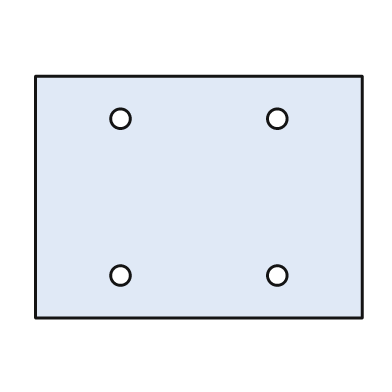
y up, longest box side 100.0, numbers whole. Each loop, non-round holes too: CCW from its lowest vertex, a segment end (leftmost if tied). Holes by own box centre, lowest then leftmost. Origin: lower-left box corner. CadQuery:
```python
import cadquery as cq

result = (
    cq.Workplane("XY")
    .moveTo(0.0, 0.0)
    .lineTo(100.0, 0.0)
    .lineTo(100.0, 74.0)
    .lineTo(0.0, 74.0)
    .close()
    .moveTo(26.0, 13.0)
    .circle(3.0)
    .moveTo(74.0, 13.0)
    .circle(3.0)
    .moveTo(26.0, 61.0)
    .circle(3.0)
    .moveTo(74.0, 61.0)
    .circle(3.0)
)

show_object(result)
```